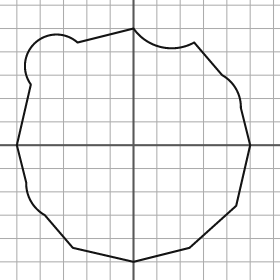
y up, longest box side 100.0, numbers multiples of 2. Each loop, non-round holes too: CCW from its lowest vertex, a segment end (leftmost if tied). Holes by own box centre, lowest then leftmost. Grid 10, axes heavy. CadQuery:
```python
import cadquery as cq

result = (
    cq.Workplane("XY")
    .moveTo(0.0, -50.0)
    .lineTo(24.0, -44.0)
    .lineTo(44.0, -26.0)
    .lineTo(50.0, 0.0)
    .lineTo(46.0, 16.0)
    .threePointArc((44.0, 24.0), (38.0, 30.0))
    .lineTo(26.0, 44.0)
    .threePointArc((12.0, 42.0), (0.0, 50.0))
    .lineTo(-24.0, 44.0)
    .threePointArc((-42.0, 44.0), (-44.0, 26.0))
    .lineTo(-50.0, 0.0)
    .lineTo(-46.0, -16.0)
    .threePointArc((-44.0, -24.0), (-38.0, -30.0))
    .lineTo(-26.0, -44.0)
    .close()
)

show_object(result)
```